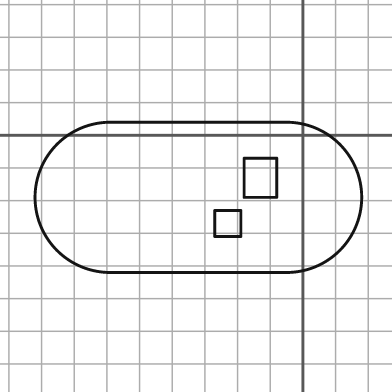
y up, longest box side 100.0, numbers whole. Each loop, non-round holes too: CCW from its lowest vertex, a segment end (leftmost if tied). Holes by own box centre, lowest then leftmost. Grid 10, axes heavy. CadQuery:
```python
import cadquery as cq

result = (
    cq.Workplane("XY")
    .moveTo(-59.0, -42.0)
    .lineTo(-5.0, -42.0)
    .threePointArc((18.0, -19.0), (-5.0, 4.0))
    .lineTo(-59.0, 4.0)
    .threePointArc((-82.0, -19.0), (-59.0, -42.0))
    .close()
    .moveTo(-27.0, -31.0)
    .lineTo(-19.0, -31.0)
    .lineTo(-19.0, -23.0)
    .lineTo(-27.0, -23.0)
    .close()
    .moveTo(-18.0, -19.0)
    .lineTo(-8.0, -19.0)
    .lineTo(-8.0, -7.0)
    .lineTo(-18.0, -7.0)
    .close()
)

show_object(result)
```